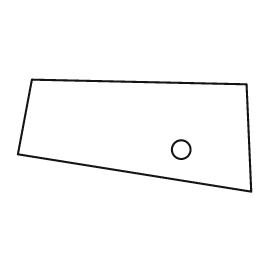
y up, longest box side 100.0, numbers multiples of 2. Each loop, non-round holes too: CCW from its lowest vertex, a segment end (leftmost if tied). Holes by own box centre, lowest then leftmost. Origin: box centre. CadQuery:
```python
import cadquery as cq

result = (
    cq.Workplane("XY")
    .moveTo(50.0, -24.0)
    .lineTo(48.0, 22.0)
    .lineTo(-44.0, 24.0)
    .lineTo(-50.0, -8.0)
    .close()
    .moveTo(20.0, -6.0)
    .circle(4.0)
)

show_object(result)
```